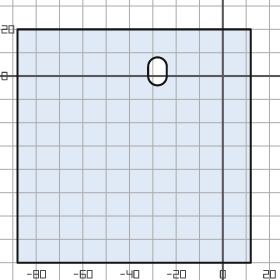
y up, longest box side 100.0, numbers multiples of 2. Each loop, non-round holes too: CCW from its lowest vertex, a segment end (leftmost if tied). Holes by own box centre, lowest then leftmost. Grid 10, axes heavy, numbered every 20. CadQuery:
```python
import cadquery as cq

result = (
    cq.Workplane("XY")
    .moveTo(-88.0, -80.0)
    .lineTo(12.0, -80.0)
    .lineTo(12.0, 20.0)
    .lineTo(-88.0, 20.0)
    .close()
    .moveTo(-32.0, 0.0)
    .threePointArc((-28.0, -4.0), (-24.0, 0.0))
    .lineTo(-24.0, 4.0)
    .threePointArc((-28.0, 8.0), (-32.0, 4.0))
    .close()
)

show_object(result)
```